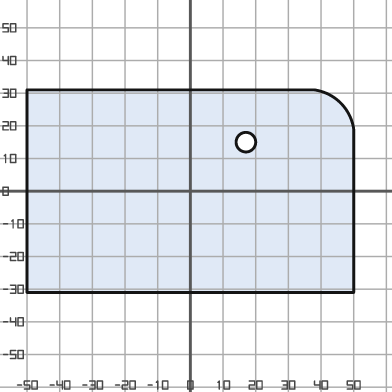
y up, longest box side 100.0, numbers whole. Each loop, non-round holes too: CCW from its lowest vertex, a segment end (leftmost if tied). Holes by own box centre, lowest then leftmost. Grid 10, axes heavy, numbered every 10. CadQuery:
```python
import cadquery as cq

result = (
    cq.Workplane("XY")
    .moveTo(-50.0, -31.0)
    .lineTo(50.0, -31.0)
    .lineTo(50.0, 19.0)
    .threePointArc((46.0, 27.0), (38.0, 31.0))
    .lineTo(-50.0, 31.0)
    .close()
    .moveTo(17.0, 15.0)
    .circle(3.0)
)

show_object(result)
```